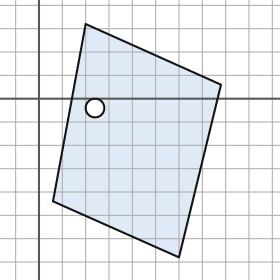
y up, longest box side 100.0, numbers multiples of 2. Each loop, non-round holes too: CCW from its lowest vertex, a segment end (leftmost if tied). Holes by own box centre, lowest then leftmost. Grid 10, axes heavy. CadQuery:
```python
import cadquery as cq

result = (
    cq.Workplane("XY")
    .moveTo(60.0, -68.0)
    .lineTo(78.0, 6.0)
    .lineTo(20.0, 32.0)
    .lineTo(6.0, -44.0)
    .close()
    .moveTo(24.0, -4.0)
    .circle(4.0)
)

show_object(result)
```